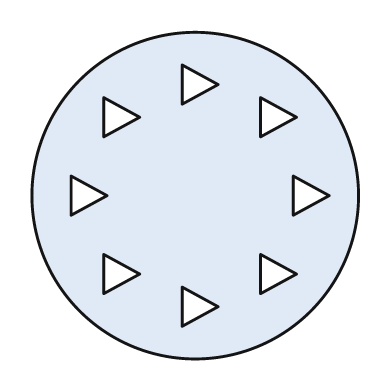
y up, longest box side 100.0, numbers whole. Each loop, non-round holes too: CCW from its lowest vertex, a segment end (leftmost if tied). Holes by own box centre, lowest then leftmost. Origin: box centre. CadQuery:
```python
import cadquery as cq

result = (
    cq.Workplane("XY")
    .moveTo(0.0, 0.0)
    .circle(50.0)
    .moveTo(-4.0, -40.0)
    .lineTo(7.0, -34.0)
    .lineTo(-4.0, -28.0)
    .close()
    .moveTo(-28.0, -30.0)
    .lineTo(-17.0, -24.0)
    .lineTo(-28.0, -18.0)
    .close()
    .moveTo(20.0, -30.0)
    .lineTo(31.0, -24.0)
    .lineTo(20.0, -18.0)
    .close()
    .moveTo(-38.0, -6.0)
    .lineTo(-27.0, 0.0)
    .lineTo(-38.0, 6.0)
    .close()
    .moveTo(30.0, -6.0)
    .lineTo(41.0, 0.0)
    .lineTo(30.0, 6.0)
    .close()
    .moveTo(-28.0, 18.0)
    .lineTo(-17.0, 24.0)
    .lineTo(-28.0, 30.0)
    .close()
    .moveTo(20.0, 18.0)
    .lineTo(31.0, 24.0)
    .lineTo(20.0, 30.0)
    .close()
    .moveTo(-4.0, 28.0)
    .lineTo(7.0, 34.0)
    .lineTo(-4.0, 40.0)
    .close()
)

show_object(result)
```